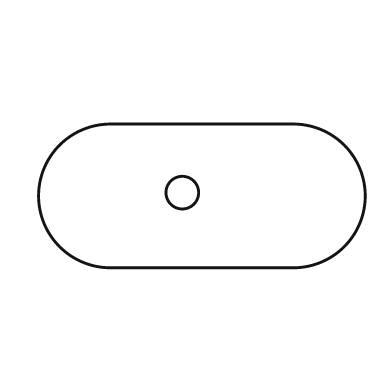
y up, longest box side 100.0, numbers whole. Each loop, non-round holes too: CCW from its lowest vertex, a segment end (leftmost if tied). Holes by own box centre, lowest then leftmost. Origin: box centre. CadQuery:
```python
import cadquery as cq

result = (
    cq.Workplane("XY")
    .moveTo(-28.0, -22.0)
    .lineTo(28.0, -22.0)
    .threePointArc((50.0, 0.0), (28.0, 22.0))
    .lineTo(-28.0, 22.0)
    .threePointArc((-50.0, 0.0), (-28.0, -22.0))
    .close()
    .moveTo(-6.0, 1.0)
    .circle(5.0)
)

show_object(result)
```